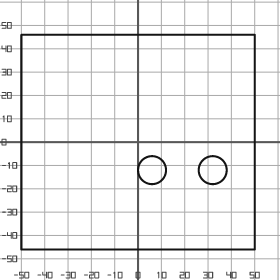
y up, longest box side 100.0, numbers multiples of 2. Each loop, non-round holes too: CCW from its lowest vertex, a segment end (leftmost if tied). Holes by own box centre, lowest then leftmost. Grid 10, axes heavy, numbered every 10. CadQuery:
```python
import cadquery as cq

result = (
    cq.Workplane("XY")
    .moveTo(-50.0, -46.0)
    .lineTo(50.0, -46.0)
    .lineTo(50.0, 46.0)
    .lineTo(-50.0, 46.0)
    .close()
    .moveTo(6.0, -12.0)
    .circle(6.0)
    .moveTo(32.0, -12.0)
    .circle(6.0)
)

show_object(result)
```